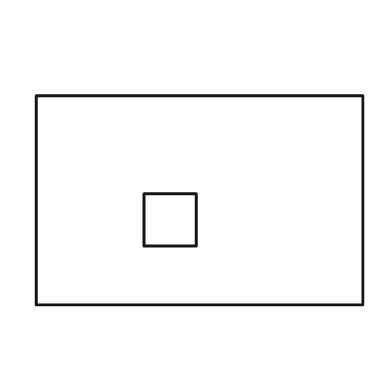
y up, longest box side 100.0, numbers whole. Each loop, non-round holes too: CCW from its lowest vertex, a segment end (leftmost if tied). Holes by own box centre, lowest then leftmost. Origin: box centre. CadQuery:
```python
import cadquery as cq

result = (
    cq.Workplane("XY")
    .moveTo(-50.0, -32.0)
    .lineTo(50.0, -32.0)
    .lineTo(50.0, 32.0)
    .lineTo(-50.0, 32.0)
    .close()
    .moveTo(-17.0, -14.0)
    .lineTo(-1.0, -14.0)
    .lineTo(-1.0, 2.0)
    .lineTo(-17.0, 2.0)
    .close()
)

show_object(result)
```